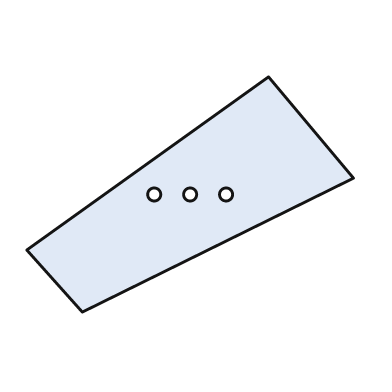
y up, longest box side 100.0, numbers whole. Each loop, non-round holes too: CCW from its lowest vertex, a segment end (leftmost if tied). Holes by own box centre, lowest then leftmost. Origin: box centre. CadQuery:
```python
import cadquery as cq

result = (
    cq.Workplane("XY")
    .moveTo(-33.0, -36.0)
    .lineTo(50.0, 5.0)
    .lineTo(24.0, 36.0)
    .lineTo(-50.0, -17.0)
    .close()
    .moveTo(-11.0, 0.0)
    .circle(2.0)
    .moveTo(0.0, 0.0)
    .circle(2.0)
    .moveTo(11.0, 0.0)
    .circle(2.0)
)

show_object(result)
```